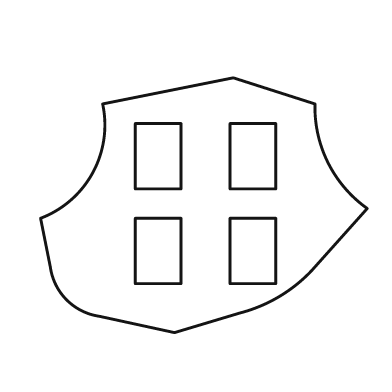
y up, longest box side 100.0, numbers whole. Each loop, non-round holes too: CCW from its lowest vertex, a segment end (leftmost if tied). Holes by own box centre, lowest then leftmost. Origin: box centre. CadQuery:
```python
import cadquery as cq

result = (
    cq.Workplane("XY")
    .moveTo(-9.0, -39.0)
    .lineTo(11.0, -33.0)
    .threePointArc((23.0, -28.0), (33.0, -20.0))
    .lineTo(50.0, -1.0)
    .threePointArc((38.0, 13.0), (34.0, 31.0))
    .lineTo(9.0, 39.0)
    .lineTo(-31.0, 31.0)
    .threePointArc((-34.0, 10.0), (-50.0, -4.0))
    .lineTo(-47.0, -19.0)
    .threePointArc((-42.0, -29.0), (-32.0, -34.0))
    .close()
    .moveTo(-21.0, -24.0)
    .lineTo(-7.0, -24.0)
    .lineTo(-7.0, -4.0)
    .lineTo(-21.0, -4.0)
    .close()
    .moveTo(8.0, -24.0)
    .lineTo(22.0, -24.0)
    .lineTo(22.0, -4.0)
    .lineTo(8.0, -4.0)
    .close()
    .moveTo(-21.0, 5.0)
    .lineTo(-7.0, 5.0)
    .lineTo(-7.0, 25.0)
    .lineTo(-21.0, 25.0)
    .close()
    .moveTo(8.0, 5.0)
    .lineTo(22.0, 5.0)
    .lineTo(22.0, 25.0)
    .lineTo(8.0, 25.0)
    .close()
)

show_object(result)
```